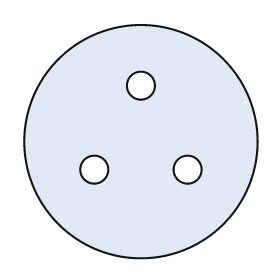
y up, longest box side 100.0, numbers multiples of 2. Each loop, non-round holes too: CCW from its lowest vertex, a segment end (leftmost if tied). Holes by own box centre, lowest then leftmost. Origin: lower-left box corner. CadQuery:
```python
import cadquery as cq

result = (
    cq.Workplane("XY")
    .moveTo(50.0, 50.0)
    .circle(50.0)
    .moveTo(30.0, 38.0)
    .circle(6.0)
    .moveTo(70.0, 38.0)
    .circle(6.0)
    .moveTo(50.0, 74.0)
    .circle(6.0)
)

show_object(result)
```